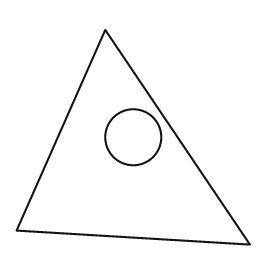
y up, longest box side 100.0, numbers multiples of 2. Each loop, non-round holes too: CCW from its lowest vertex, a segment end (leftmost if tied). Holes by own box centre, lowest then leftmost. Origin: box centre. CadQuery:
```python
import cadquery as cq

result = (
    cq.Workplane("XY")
    .moveTo(50.0, -46.0)
    .lineTo(-12.0, 46.0)
    .lineTo(-50.0, -40.0)
    .close()
    .moveTo(0.0, 0.0)
    .circle(12.0)
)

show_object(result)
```